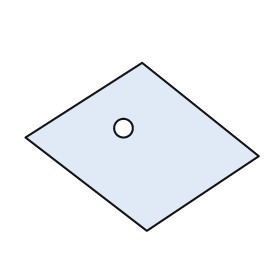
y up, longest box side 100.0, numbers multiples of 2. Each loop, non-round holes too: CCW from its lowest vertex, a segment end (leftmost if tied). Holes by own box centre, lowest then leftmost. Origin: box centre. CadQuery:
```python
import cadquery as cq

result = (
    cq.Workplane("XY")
    .moveTo(2.0, -36.0)
    .lineTo(50.0, -4.0)
    .lineTo(0.0, 36.0)
    .lineTo(-50.0, 4.0)
    .close()
    .moveTo(-8.0, 8.0)
    .circle(4.0)
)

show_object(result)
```